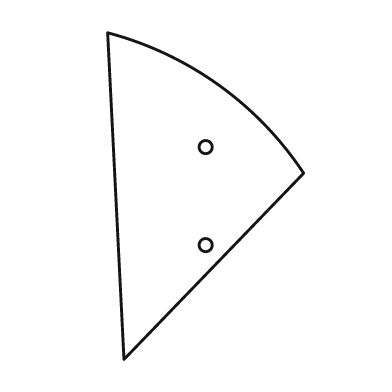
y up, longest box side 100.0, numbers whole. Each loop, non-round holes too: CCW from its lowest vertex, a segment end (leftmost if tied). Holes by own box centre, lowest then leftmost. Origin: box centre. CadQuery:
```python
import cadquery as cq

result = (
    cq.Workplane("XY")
    .moveTo(-25.0, -50.0)
    .lineTo(30.0, 7.0)
    .threePointArc((4.0, 34.0), (-30.0, 50.0))
    .close()
    .moveTo(0.0, -15.0)
    .circle(2.0)
    .moveTo(0.0, 15.0)
    .circle(2.0)
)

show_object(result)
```